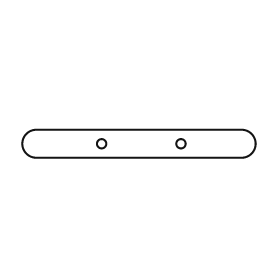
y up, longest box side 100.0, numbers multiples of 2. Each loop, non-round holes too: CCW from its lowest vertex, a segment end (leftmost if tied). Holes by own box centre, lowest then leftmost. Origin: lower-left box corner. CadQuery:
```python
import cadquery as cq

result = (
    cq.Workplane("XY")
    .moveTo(6.0, 0.0)
    .lineTo(94.0, 0.0)
    .threePointArc((100.0, 6.0), (94.0, 12.0))
    .lineTo(6.0, 12.0)
    .threePointArc((0.0, 6.0), (6.0, 0.0))
    .close()
    .moveTo(34.0, 6.0)
    .circle(2.0)
    .moveTo(68.0, 6.0)
    .circle(2.0)
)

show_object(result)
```